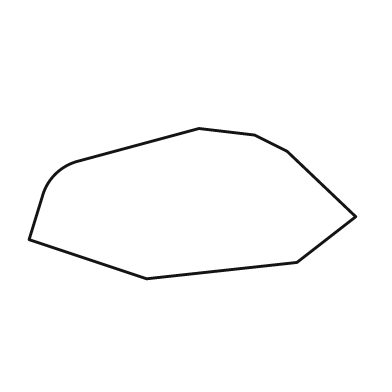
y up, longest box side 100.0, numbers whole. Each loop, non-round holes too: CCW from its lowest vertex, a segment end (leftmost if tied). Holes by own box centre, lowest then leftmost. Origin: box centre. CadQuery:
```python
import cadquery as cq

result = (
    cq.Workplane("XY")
    .moveTo(-14.0, -23.0)
    .lineTo(32.0, -18.0)
    .lineTo(50.0, -4.0)
    .lineTo(29.0, 16.0)
    .lineTo(19.0, 21.0)
    .lineTo(2.0, 23.0)
    .lineTo(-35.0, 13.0)
    .threePointArc((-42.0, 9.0), (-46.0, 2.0))
    .lineTo(-50.0, -11.0)
    .close()
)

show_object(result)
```